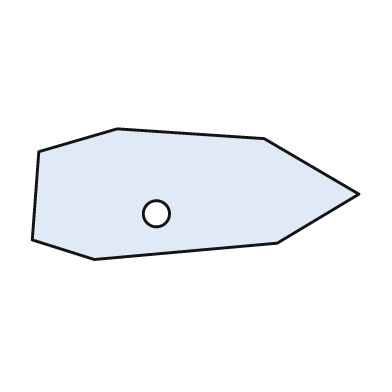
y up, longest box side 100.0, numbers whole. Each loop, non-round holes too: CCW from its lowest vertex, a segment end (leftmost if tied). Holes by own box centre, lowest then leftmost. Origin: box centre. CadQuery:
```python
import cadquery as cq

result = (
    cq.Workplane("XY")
    .moveTo(-31.0, -20.0)
    .lineTo(25.0, -15.0)
    .lineTo(50.0, 0.0)
    .lineTo(21.0, 17.0)
    .lineTo(-24.0, 20.0)
    .lineTo(-48.0, 13.0)
    .lineTo(-50.0, -14.0)
    .close()
    .moveTo(-12.0, -6.0)
    .circle(4.0)
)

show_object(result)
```